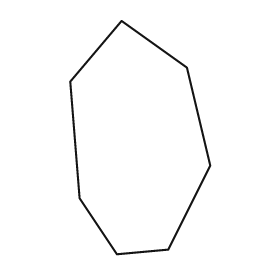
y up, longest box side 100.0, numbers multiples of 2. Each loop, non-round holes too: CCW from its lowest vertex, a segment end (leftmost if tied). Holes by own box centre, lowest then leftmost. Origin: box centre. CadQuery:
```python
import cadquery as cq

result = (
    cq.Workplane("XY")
    .moveTo(-10.0, -50.0)
    .lineTo(12.0, -48.0)
    .lineTo(30.0, -12.0)
    .lineTo(20.0, 30.0)
    .lineTo(-8.0, 50.0)
    .lineTo(-30.0, 24.0)
    .lineTo(-26.0, -26.0)
    .close()
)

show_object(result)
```